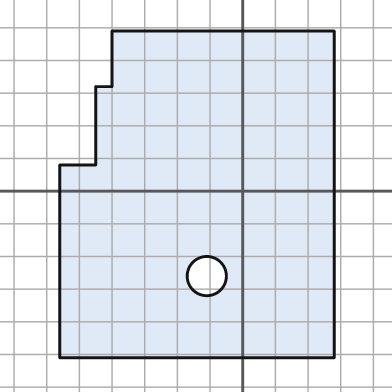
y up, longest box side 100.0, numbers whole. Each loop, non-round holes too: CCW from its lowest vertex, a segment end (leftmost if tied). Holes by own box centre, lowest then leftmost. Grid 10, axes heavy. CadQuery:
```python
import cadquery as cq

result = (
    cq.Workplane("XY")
    .moveTo(-56.0, -51.0)
    .lineTo(28.0, -51.0)
    .lineTo(28.0, 49.0)
    .lineTo(-40.0, 49.0)
    .lineTo(-40.0, 32.0)
    .lineTo(-45.0, 32.0)
    .lineTo(-45.0, 8.0)
    .lineTo(-56.0, 8.0)
    .close()
    .moveTo(-11.0, -26.0)
    .circle(6.0)
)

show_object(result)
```